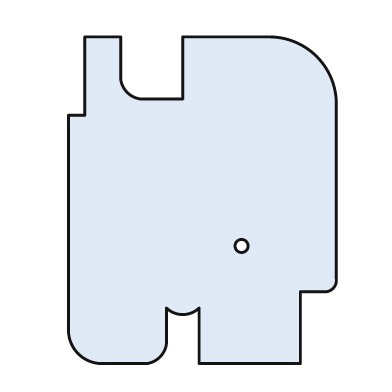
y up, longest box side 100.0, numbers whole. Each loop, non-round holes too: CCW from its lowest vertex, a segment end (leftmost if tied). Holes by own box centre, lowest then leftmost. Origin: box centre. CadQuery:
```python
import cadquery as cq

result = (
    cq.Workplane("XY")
    .moveTo(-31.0, -50.0)
    .lineTo(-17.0, -50.0)
    .threePointArc((-13.0, -48.0), (-11.0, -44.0))
    .lineTo(-11.0, -33.0)
    .threePointArc((-6.0, -35.0), (-1.0, -33.0))
    .lineTo(-1.0, -50.0)
    .lineTo(30.0, -50.0)
    .lineTo(30.0, -28.0)
    .lineTo(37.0, -28.0)
    .threePointArc((40.0, -27.0), (41.0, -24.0))
    .lineTo(41.0, 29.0)
    .threePointArc((35.0, 44.0), (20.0, 50.0))
    .lineTo(-6.0, 50.0)
    .lineTo(-6.0, 31.0)
    .lineTo(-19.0, 31.0)
    .threePointArc((-23.0, 33.0), (-25.0, 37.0))
    .lineTo(-25.0, 50.0)
    .lineTo(-36.0, 50.0)
    .lineTo(-36.0, 26.0)
    .lineTo(-41.0, 26.0)
    .lineTo(-41.0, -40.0)
    .threePointArc((-38.0, -47.0), (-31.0, -50.0))
    .close()
    .moveTo(12.0, -14.0)
    .circle(2.0)
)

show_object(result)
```